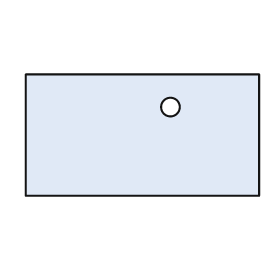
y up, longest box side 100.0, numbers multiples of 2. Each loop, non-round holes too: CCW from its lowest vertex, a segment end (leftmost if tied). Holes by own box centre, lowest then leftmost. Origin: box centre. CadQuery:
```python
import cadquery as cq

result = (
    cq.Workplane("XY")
    .moveTo(-50.0, -26.0)
    .lineTo(50.0, -26.0)
    .lineTo(50.0, 26.0)
    .lineTo(-50.0, 26.0)
    .close()
    .moveTo(12.0, 12.0)
    .circle(4.0)
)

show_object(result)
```